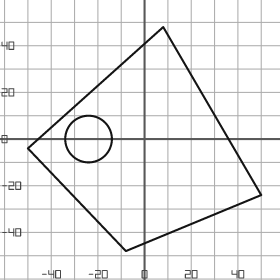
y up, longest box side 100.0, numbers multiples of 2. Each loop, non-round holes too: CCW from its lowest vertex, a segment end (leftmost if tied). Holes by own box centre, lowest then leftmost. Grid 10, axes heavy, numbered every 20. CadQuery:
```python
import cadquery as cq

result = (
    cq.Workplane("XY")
    .moveTo(-8.0, -48.0)
    .lineTo(50.0, -24.0)
    .lineTo(8.0, 48.0)
    .lineTo(-50.0, -4.0)
    .close()
    .moveTo(-24.0, 0.0)
    .circle(10.0)
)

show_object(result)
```